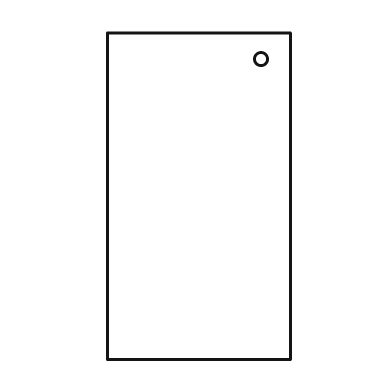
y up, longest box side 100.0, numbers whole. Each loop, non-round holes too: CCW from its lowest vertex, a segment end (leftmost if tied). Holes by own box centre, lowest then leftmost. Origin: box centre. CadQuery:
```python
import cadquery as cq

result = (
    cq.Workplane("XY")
    .moveTo(-28.0, -50.0)
    .lineTo(28.0, -50.0)
    .lineTo(28.0, 50.0)
    .lineTo(-28.0, 50.0)
    .close()
    .moveTo(19.0, 42.0)
    .circle(2.0)
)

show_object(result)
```